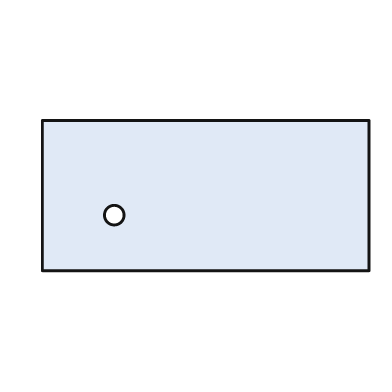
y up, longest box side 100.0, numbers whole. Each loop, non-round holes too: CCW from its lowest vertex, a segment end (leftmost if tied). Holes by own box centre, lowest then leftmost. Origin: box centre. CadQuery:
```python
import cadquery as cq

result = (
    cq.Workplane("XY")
    .moveTo(-50.0, -23.0)
    .lineTo(50.0, -23.0)
    .lineTo(50.0, 23.0)
    .lineTo(-50.0, 23.0)
    .close()
    .moveTo(-28.0, -6.0)
    .circle(3.0)
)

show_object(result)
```